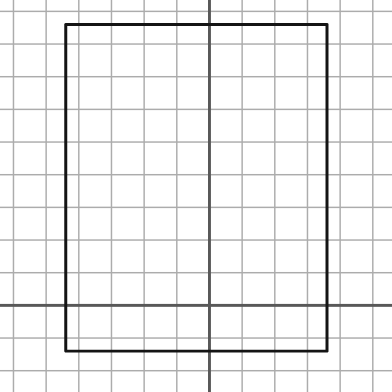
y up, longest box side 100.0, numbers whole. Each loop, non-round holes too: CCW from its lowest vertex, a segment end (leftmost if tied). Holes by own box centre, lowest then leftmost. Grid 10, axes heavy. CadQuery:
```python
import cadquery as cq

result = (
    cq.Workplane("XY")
    .moveTo(-44.0, -14.0)
    .lineTo(36.0, -14.0)
    .lineTo(36.0, 86.0)
    .lineTo(-44.0, 86.0)
    .close()
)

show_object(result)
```